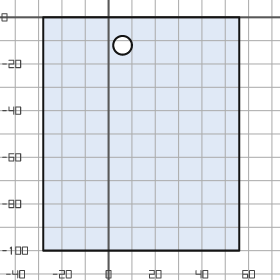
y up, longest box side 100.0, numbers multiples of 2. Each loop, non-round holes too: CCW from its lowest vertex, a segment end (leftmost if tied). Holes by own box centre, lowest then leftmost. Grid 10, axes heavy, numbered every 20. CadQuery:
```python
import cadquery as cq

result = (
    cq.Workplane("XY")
    .moveTo(-28.0, -100.0)
    .lineTo(56.0, -100.0)
    .lineTo(56.0, 0.0)
    .lineTo(-28.0, 0.0)
    .close()
    .moveTo(6.0, -12.0)
    .circle(4.0)
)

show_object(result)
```